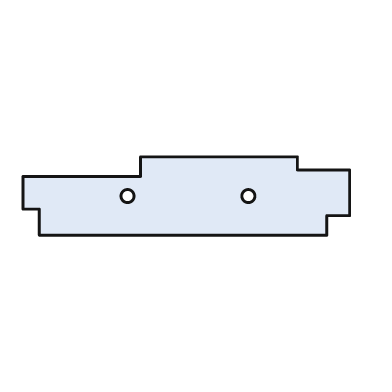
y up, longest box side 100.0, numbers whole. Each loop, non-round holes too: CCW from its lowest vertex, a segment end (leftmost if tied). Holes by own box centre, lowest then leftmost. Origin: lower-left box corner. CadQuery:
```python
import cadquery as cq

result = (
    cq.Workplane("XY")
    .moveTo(5.0, 0.0)
    .lineTo(93.0, 0.0)
    .lineTo(93.0, 6.0)
    .lineTo(100.0, 6.0)
    .lineTo(100.0, 20.0)
    .lineTo(84.0, 20.0)
    .lineTo(84.0, 24.0)
    .lineTo(36.0, 24.0)
    .lineTo(36.0, 18.0)
    .lineTo(0.0, 18.0)
    .lineTo(0.0, 8.0)
    .lineTo(5.0, 8.0)
    .close()
    .moveTo(32.0, 12.0)
    .circle(2.0)
    .moveTo(69.0, 12.0)
    .circle(2.0)
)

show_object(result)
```